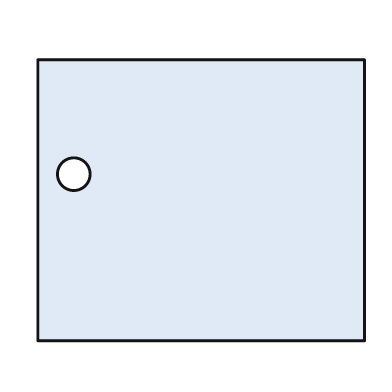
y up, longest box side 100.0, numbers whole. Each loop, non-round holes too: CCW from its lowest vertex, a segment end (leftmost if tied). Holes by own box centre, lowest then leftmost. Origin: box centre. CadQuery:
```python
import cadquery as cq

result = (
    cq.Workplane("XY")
    .moveTo(-50.0, -43.0)
    .lineTo(50.0, -43.0)
    .lineTo(50.0, 43.0)
    .lineTo(-50.0, 43.0)
    .close()
    .moveTo(-39.0, 8.0)
    .circle(5.0)
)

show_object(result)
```